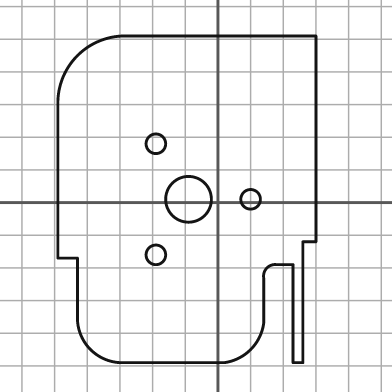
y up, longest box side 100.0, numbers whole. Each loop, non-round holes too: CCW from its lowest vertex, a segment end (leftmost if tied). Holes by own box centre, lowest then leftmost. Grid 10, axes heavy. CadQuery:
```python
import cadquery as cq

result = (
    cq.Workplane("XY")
    .moveTo(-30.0, -49.0)
    .lineTo(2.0, -49.0)
    .threePointArc((10.0, -45.0), (14.0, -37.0))
    .lineTo(14.0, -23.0)
    .threePointArc((15.0, -20.0), (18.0, -19.0))
    .lineTo(23.0, -19.0)
    .lineTo(23.0, -49.0)
    .lineTo(26.0, -49.0)
    .lineTo(26.0, -12.0)
    .lineTo(30.0, -12.0)
    .lineTo(30.0, 51.0)
    .lineTo(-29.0, 51.0)
    .threePointArc((-43.0, 45.0), (-49.0, 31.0))
    .lineTo(-49.0, -17.0)
    .lineTo(-43.0, -17.0)
    .lineTo(-43.0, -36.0)
    .threePointArc((-39.0, -45.0), (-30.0, -49.0))
    .close()
    .moveTo(-19.0, -16.0)
    .circle(3.0)
    .moveTo(-9.0, 1.0)
    .circle(7.0)
    .moveTo(10.0, 1.0)
    .circle(3.0)
    .moveTo(-19.0, 18.0)
    .circle(3.0)
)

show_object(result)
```